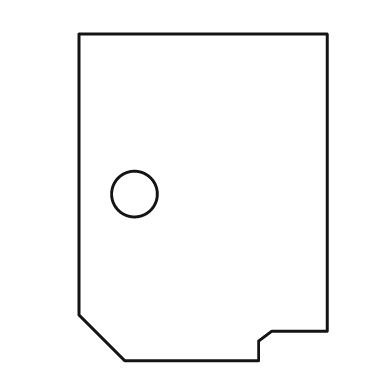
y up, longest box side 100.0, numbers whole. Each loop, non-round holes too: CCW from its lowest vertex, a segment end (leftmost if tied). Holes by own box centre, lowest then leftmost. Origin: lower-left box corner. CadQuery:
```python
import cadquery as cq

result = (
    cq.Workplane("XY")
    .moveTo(14.0, 0.0)
    .lineTo(55.0, 0.0)
    .lineTo(55.0, 6.0)
    .lineTo(59.0, 9.0)
    .lineTo(76.0, 9.0)
    .lineTo(76.0, 100.0)
    .lineTo(0.0, 100.0)
    .lineTo(0.0, 14.0)
    .close()
    .moveTo(17.0, 51.0)
    .circle(7.0)
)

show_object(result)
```